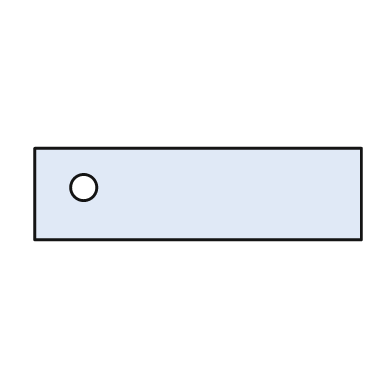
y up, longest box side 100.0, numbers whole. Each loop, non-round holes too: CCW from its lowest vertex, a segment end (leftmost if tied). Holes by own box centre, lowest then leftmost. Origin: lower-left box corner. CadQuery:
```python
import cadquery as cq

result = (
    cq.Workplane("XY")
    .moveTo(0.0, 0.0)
    .lineTo(100.0, 0.0)
    .lineTo(100.0, 28.0)
    .lineTo(0.0, 28.0)
    .close()
    .moveTo(15.0, 16.0)
    .circle(4.0)
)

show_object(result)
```